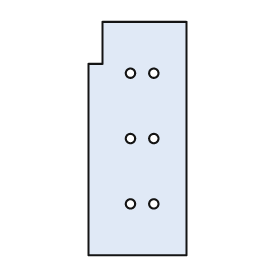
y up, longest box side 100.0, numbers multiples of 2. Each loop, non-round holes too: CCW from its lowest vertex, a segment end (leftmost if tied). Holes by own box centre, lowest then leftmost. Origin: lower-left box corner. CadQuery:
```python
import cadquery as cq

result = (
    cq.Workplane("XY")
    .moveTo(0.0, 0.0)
    .lineTo(42.0, 0.0)
    .lineTo(42.0, 100.0)
    .lineTo(6.0, 100.0)
    .lineTo(6.0, 82.0)
    .lineTo(0.0, 82.0)
    .close()
    .moveTo(18.0, 22.0)
    .circle(2.0)
    .moveTo(28.0, 22.0)
    .circle(2.0)
    .moveTo(18.0, 50.0)
    .circle(2.0)
    .moveTo(28.0, 50.0)
    .circle(2.0)
    .moveTo(18.0, 78.0)
    .circle(2.0)
    .moveTo(28.0, 78.0)
    .circle(2.0)
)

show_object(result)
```